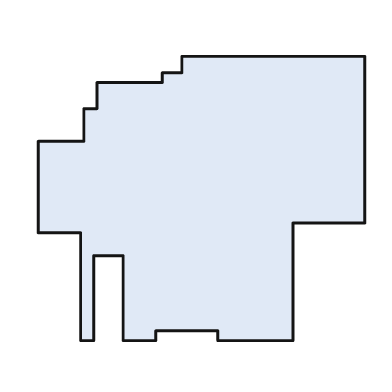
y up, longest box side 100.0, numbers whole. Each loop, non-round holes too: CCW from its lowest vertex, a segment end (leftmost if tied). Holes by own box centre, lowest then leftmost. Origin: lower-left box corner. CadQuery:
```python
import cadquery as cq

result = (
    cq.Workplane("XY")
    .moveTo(13.0, 0.0)
    .lineTo(17.0, 0.0)
    .lineTo(17.0, 26.0)
    .lineTo(26.0, 26.0)
    .lineTo(26.0, 0.0)
    .lineTo(36.0, 0.0)
    .lineTo(36.0, 3.0)
    .lineTo(55.0, 3.0)
    .lineTo(55.0, 0.0)
    .lineTo(78.0, 0.0)
    .lineTo(78.0, 36.0)
    .lineTo(100.0, 36.0)
    .lineTo(100.0, 87.0)
    .lineTo(44.0, 87.0)
    .lineTo(44.0, 82.0)
    .lineTo(38.0, 82.0)
    .lineTo(38.0, 79.0)
    .lineTo(18.0, 79.0)
    .lineTo(18.0, 71.0)
    .lineTo(14.0, 71.0)
    .lineTo(14.0, 61.0)
    .lineTo(0.0, 61.0)
    .lineTo(0.0, 33.0)
    .lineTo(13.0, 33.0)
    .close()
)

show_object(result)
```